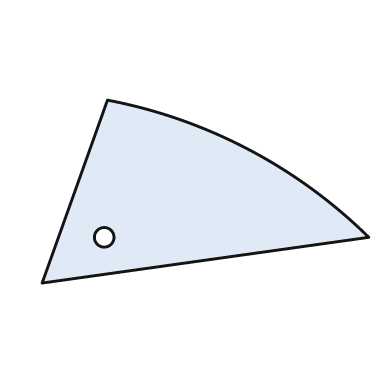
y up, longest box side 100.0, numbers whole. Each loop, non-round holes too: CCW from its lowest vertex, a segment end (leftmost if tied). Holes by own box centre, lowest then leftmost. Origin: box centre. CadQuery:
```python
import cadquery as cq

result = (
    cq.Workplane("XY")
    .moveTo(-50.0, -28.0)
    .lineTo(50.0, -14.0)
    .threePointArc((13.0, 13.0), (-30.0, 28.0))
    .close()
    .moveTo(-31.0, -14.0)
    .circle(3.0)
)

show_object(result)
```